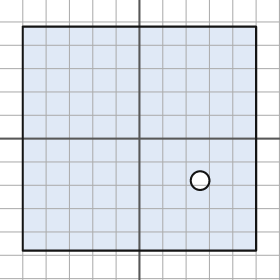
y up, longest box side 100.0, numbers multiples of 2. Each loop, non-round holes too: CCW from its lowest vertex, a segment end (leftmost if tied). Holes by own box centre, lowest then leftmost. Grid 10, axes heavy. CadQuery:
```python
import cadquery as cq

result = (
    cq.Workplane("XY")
    .moveTo(-50.0, -48.0)
    .lineTo(50.0, -48.0)
    .lineTo(50.0, 48.0)
    .lineTo(-50.0, 48.0)
    .close()
    .moveTo(26.0, -18.0)
    .circle(4.0)
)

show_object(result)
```